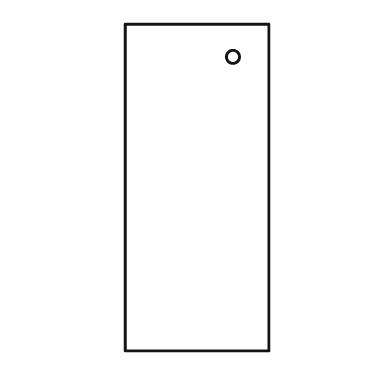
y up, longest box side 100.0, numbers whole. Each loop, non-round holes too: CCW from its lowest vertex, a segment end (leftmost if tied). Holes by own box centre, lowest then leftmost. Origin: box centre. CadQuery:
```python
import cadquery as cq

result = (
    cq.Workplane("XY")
    .moveTo(-22.0, -50.0)
    .lineTo(22.0, -50.0)
    .lineTo(22.0, 50.0)
    .lineTo(-22.0, 50.0)
    .close()
    .moveTo(11.0, 40.0)
    .circle(2.0)
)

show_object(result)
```